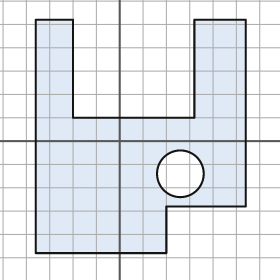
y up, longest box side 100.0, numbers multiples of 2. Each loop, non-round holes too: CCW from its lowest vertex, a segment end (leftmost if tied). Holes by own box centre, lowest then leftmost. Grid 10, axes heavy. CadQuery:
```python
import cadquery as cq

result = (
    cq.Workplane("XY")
    .moveTo(-36.0, -48.0)
    .lineTo(20.0, -48.0)
    .lineTo(20.0, -28.0)
    .lineTo(54.0, -28.0)
    .lineTo(54.0, 52.0)
    .lineTo(32.0, 52.0)
    .lineTo(32.0, 10.0)
    .lineTo(-20.0, 10.0)
    .lineTo(-20.0, 52.0)
    .lineTo(-36.0, 52.0)
    .close()
    .moveTo(26.0, -14.0)
    .circle(10.0)
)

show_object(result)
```